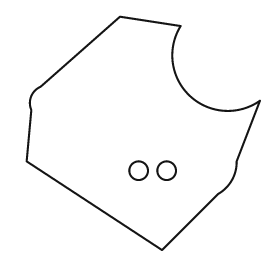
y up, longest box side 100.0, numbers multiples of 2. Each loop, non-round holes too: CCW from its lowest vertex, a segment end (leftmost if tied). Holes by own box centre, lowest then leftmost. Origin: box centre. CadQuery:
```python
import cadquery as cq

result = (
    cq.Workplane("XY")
    .moveTo(8.0, -50.0)
    .lineTo(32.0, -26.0)
    .threePointArc((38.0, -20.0), (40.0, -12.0))
    .lineTo(50.0, 14.0)
    .threePointArc((20.0, 16.0), (16.0, 46.0))
    .lineTo(-10.0, 50.0)
    .lineTo(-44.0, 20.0)
    .threePointArc((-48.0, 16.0), (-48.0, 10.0))
    .lineTo(-50.0, -12.0)
    .close()
    .moveTo(-2.0, -16.0)
    .circle(4.0)
    .moveTo(10.0, -16.0)
    .circle(4.0)
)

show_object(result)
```